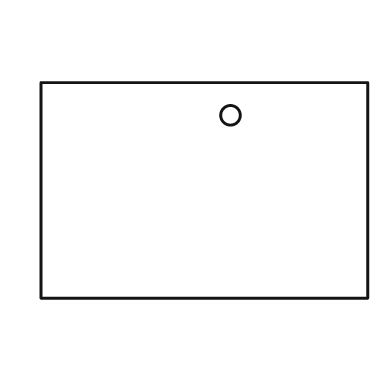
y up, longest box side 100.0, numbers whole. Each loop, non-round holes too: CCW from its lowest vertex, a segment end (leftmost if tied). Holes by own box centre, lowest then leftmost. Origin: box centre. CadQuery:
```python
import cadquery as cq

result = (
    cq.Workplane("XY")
    .moveTo(-50.0, -33.0)
    .lineTo(50.0, -33.0)
    .lineTo(50.0, 33.0)
    .lineTo(-50.0, 33.0)
    .close()
    .moveTo(8.0, 23.0)
    .circle(3.0)
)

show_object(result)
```